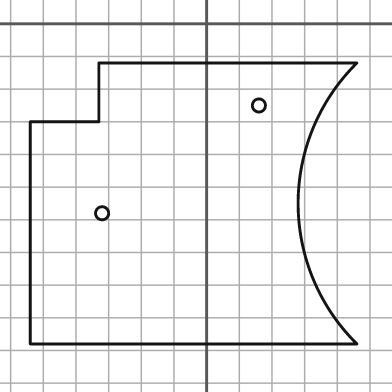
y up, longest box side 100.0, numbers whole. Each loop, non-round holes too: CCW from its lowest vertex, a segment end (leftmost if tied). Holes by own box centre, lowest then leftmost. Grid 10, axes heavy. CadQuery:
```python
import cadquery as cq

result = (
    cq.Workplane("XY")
    .moveTo(-54.0, -98.0)
    .lineTo(46.0, -98.0)
    .threePointArc((28.0, -55.0), (46.0, -12.0))
    .lineTo(-33.0, -12.0)
    .lineTo(-33.0, -30.0)
    .lineTo(-54.0, -30.0)
    .close()
    .moveTo(-32.0, -58.0)
    .circle(2.0)
    .moveTo(16.0, -25.0)
    .circle(2.0)
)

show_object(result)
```